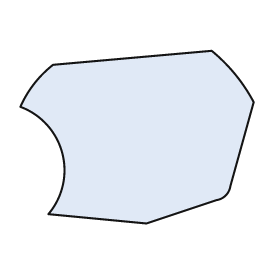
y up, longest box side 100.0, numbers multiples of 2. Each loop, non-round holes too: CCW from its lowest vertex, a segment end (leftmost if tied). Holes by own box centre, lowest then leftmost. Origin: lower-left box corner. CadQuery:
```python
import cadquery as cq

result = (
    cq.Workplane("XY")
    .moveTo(54.0, 0.0)
    .lineTo(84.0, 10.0)
    .threePointArc((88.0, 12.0), (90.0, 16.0))
    .lineTo(100.0, 52.0)
    .threePointArc((92.0, 64.0), (82.0, 74.0))
    .lineTo(14.0, 68.0)
    .threePointArc((6.0, 60.0), (0.0, 50.0))
    .threePointArc((18.0, 30.0), (12.0, 4.0))
    .close()
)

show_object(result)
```